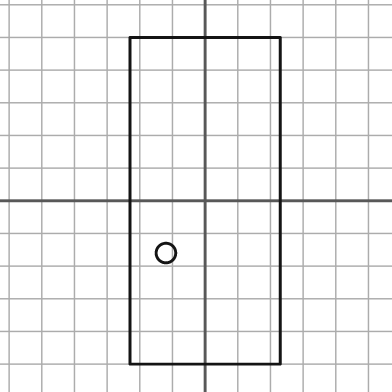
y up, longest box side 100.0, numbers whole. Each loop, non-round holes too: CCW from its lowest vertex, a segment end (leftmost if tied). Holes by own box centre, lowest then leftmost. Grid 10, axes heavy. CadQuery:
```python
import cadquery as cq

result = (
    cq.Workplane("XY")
    .moveTo(-23.0, -50.0)
    .lineTo(23.0, -50.0)
    .lineTo(23.0, 50.0)
    .lineTo(-23.0, 50.0)
    .close()
    .moveTo(-12.0, -16.0)
    .circle(3.0)
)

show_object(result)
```